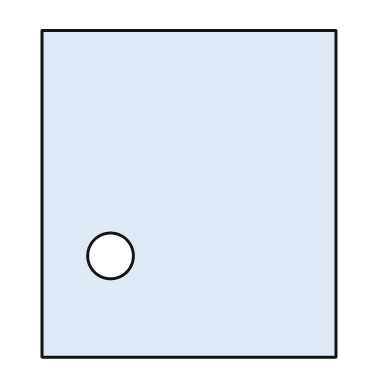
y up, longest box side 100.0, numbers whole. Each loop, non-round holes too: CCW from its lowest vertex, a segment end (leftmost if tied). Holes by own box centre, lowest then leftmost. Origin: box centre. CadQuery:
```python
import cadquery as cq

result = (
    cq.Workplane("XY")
    .moveTo(-45.0, -50.0)
    .lineTo(45.0, -50.0)
    .lineTo(45.0, 50.0)
    .lineTo(-45.0, 50.0)
    .close()
    .moveTo(-24.0, -19.0)
    .circle(7.0)
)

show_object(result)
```